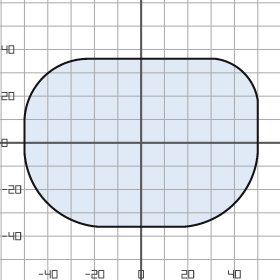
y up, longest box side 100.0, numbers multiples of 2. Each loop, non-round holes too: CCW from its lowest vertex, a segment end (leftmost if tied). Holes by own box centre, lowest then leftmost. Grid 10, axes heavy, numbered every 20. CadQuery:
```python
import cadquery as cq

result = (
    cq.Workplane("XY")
    .moveTo(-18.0, -36.0)
    .lineTo(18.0, -36.0)
    .threePointArc((40.0, -26.0), (50.0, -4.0))
    .lineTo(50.0, 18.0)
    .threePointArc((44.0, 30.0), (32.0, 36.0))
    .lineTo(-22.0, 36.0)
    .threePointArc((-42.0, 28.0), (-50.0, 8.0))
    .lineTo(-50.0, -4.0)
    .threePointArc((-40.0, -26.0), (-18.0, -36.0))
    .close()
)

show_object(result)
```